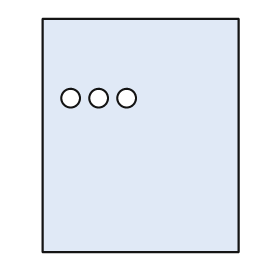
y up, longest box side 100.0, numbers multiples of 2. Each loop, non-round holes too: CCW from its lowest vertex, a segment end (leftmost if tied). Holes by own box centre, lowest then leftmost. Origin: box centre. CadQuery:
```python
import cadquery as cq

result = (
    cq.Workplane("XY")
    .moveTo(-42.0, -50.0)
    .lineTo(42.0, -50.0)
    .lineTo(42.0, 50.0)
    .lineTo(-42.0, 50.0)
    .close()
    .moveTo(-30.0, 16.0)
    .circle(4.0)
    .moveTo(-18.0, 16.0)
    .circle(4.0)
    .moveTo(-6.0, 16.0)
    .circle(4.0)
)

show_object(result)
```